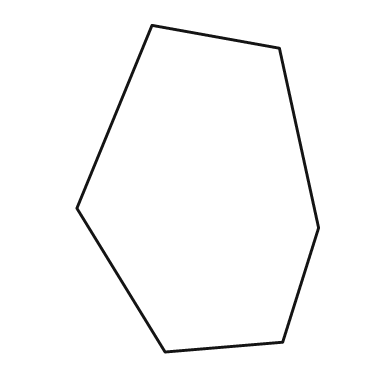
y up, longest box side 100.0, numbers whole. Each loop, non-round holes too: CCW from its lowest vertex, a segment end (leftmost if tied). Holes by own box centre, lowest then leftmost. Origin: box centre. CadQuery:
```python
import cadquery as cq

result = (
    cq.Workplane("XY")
    .moveTo(-10.0, -50.0)
    .lineTo(26.0, -47.0)
    .lineTo(37.0, -12.0)
    .lineTo(25.0, 43.0)
    .lineTo(-14.0, 50.0)
    .lineTo(-37.0, -6.0)
    .close()
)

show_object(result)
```